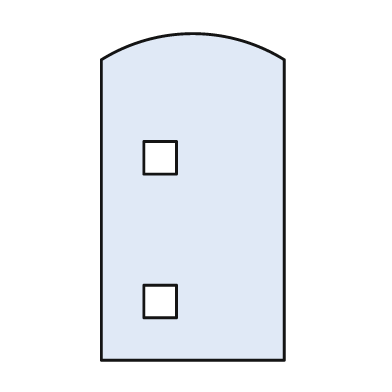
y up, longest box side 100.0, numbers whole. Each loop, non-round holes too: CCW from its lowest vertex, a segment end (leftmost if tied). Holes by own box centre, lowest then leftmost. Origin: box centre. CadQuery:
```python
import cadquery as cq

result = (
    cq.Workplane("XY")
    .moveTo(-28.0, -50.0)
    .lineTo(28.0, -50.0)
    .lineTo(28.0, 42.0)
    .threePointArc((0.0, 50.0), (-28.0, 42.0))
    .close()
    .moveTo(-15.0, -37.0)
    .lineTo(-5.0, -37.0)
    .lineTo(-5.0, -27.0)
    .lineTo(-15.0, -27.0)
    .close()
    .moveTo(-15.0, 7.0)
    .lineTo(-5.0, 7.0)
    .lineTo(-5.0, 17.0)
    .lineTo(-15.0, 17.0)
    .close()
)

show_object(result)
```